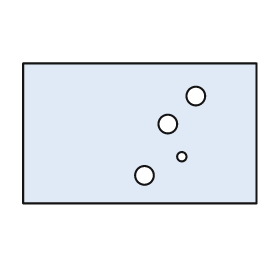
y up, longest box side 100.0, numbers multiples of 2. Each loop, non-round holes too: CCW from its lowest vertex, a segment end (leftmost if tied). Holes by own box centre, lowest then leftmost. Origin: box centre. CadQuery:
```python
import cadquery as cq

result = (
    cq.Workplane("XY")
    .moveTo(-50.0, -30.0)
    .lineTo(50.0, -30.0)
    .lineTo(50.0, 30.0)
    .lineTo(-50.0, 30.0)
    .close()
    .moveTo(2.0, -18.0)
    .circle(4.0)
    .moveTo(18.0, -10.0)
    .circle(2.0)
    .moveTo(12.0, 4.0)
    .circle(4.0)
    .moveTo(24.0, 16.0)
    .circle(4.0)
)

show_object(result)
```